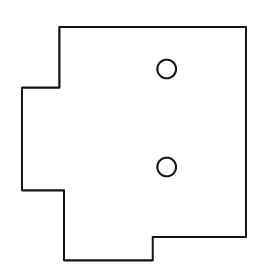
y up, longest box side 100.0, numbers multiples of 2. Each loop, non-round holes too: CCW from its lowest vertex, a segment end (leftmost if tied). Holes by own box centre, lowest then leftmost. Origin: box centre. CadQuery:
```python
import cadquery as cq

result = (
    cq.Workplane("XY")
    .moveTo(-30.0, -50.0)
    .lineTo(8.0, -50.0)
    .lineTo(8.0, -40.0)
    .lineTo(48.0, -40.0)
    .lineTo(48.0, 50.0)
    .lineTo(-32.0, 50.0)
    .lineTo(-32.0, 24.0)
    .lineTo(-48.0, 24.0)
    .lineTo(-48.0, -20.0)
    .lineTo(-30.0, -20.0)
    .close()
    .moveTo(14.0, -10.0)
    .circle(4.0)
    .moveTo(14.0, 32.0)
    .circle(4.0)
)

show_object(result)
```